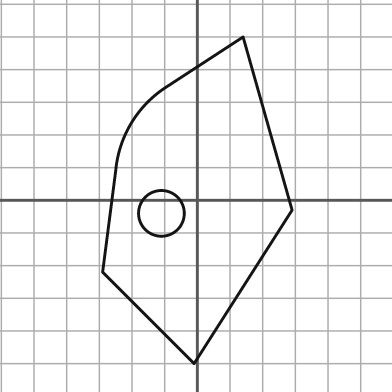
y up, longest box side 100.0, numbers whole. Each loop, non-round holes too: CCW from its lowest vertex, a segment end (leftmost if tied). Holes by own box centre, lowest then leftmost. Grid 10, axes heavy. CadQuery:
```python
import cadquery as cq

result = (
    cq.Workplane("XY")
    .moveTo(-1.0, -50.0)
    .lineTo(29.0, -3.0)
    .lineTo(14.0, 50.0)
    .lineTo(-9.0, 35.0)
    .threePointArc((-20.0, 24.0), (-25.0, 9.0))
    .lineTo(-29.0, -22.0)
    .close()
    .moveTo(-11.0, -4.0)
    .circle(7.0)
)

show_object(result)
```